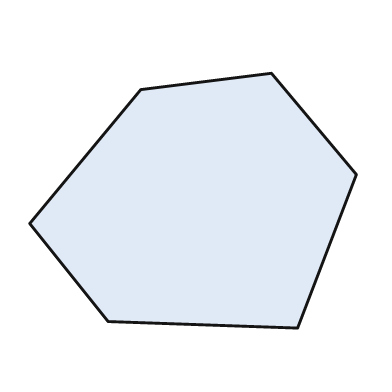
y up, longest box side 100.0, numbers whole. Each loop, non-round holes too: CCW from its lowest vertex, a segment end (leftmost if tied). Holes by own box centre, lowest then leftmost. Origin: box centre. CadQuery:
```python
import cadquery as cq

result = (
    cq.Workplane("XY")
    .moveTo(32.0, -39.0)
    .lineTo(50.0, 8.0)
    .lineTo(24.0, 39.0)
    .lineTo(-16.0, 34.0)
    .lineTo(-50.0, -7.0)
    .lineTo(-26.0, -37.0)
    .close()
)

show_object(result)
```